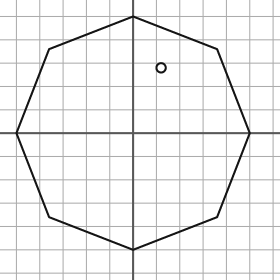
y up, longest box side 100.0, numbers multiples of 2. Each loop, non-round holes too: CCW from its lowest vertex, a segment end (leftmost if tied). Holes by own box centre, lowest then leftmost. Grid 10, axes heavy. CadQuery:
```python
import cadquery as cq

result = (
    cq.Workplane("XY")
    .moveTo(0.0, -50.0)
    .lineTo(36.0, -36.0)
    .lineTo(50.0, 0.0)
    .lineTo(36.0, 36.0)
    .lineTo(0.0, 50.0)
    .lineTo(-36.0, 36.0)
    .lineTo(-50.0, 0.0)
    .lineTo(-36.0, -36.0)
    .close()
    .moveTo(12.0, 28.0)
    .circle(2.0)
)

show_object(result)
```